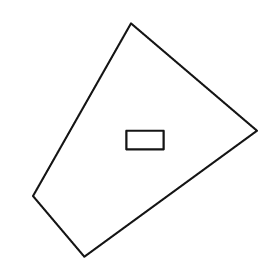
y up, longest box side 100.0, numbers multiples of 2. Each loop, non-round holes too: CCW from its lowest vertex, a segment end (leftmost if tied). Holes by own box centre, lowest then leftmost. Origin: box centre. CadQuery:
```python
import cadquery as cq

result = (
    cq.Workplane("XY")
    .moveTo(-26.0, -50.0)
    .lineTo(48.0, 4.0)
    .lineTo(-6.0, 50.0)
    .lineTo(-48.0, -24.0)
    .close()
    .moveTo(-8.0, -4.0)
    .lineTo(8.0, -4.0)
    .lineTo(8.0, 4.0)
    .lineTo(-8.0, 4.0)
    .close()
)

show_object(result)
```